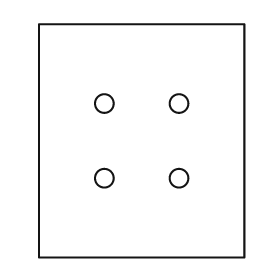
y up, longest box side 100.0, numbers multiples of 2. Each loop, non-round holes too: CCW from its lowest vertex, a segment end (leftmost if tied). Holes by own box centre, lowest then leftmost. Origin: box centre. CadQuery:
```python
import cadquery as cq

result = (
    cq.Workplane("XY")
    .moveTo(-44.0, -50.0)
    .lineTo(44.0, -50.0)
    .lineTo(44.0, 50.0)
    .lineTo(-44.0, 50.0)
    .close()
    .moveTo(-16.0, -16.0)
    .circle(4.0)
    .moveTo(16.0, -16.0)
    .circle(4.0)
    .moveTo(-16.0, 16.0)
    .circle(4.0)
    .moveTo(16.0, 16.0)
    .circle(4.0)
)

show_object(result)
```